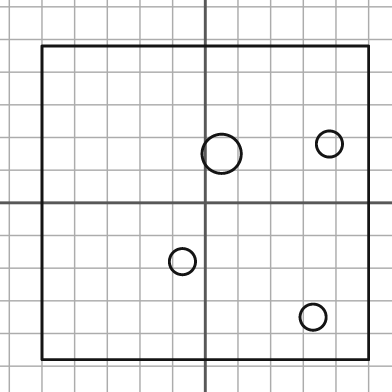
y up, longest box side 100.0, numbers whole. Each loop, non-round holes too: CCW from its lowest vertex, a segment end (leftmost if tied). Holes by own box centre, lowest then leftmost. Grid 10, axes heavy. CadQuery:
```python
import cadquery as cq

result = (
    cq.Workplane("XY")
    .moveTo(-50.0, -48.0)
    .lineTo(50.0, -48.0)
    .lineTo(50.0, 48.0)
    .lineTo(-50.0, 48.0)
    .close()
    .moveTo(33.0, -35.0)
    .circle(4.0)
    .moveTo(-7.0, -18.0)
    .circle(4.0)
    .moveTo(5.0, 15.0)
    .circle(6.0)
    .moveTo(38.0, 18.0)
    .circle(4.0)
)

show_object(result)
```